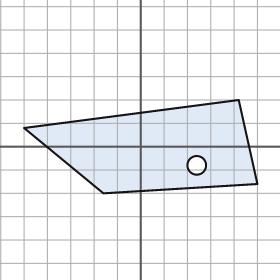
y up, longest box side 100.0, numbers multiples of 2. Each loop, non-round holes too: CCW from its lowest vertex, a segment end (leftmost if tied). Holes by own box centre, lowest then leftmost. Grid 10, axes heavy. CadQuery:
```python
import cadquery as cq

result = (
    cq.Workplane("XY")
    .moveTo(-16.0, -20.0)
    .lineTo(50.0, -16.0)
    .lineTo(42.0, 20.0)
    .lineTo(-50.0, 8.0)
    .close()
    .moveTo(24.0, -8.0)
    .circle(4.0)
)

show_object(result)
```